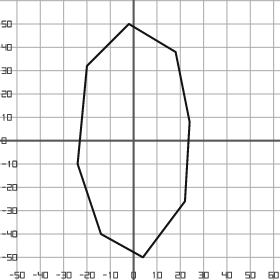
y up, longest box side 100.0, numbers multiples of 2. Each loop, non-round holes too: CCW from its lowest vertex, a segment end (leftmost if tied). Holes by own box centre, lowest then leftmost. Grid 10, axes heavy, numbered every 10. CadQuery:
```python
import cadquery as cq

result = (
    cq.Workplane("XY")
    .moveTo(4.0, -50.0)
    .lineTo(22.0, -26.0)
    .lineTo(24.0, 8.0)
    .lineTo(18.0, 38.0)
    .lineTo(-2.0, 50.0)
    .lineTo(-20.0, 32.0)
    .lineTo(-24.0, -10.0)
    .lineTo(-14.0, -40.0)
    .close()
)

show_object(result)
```